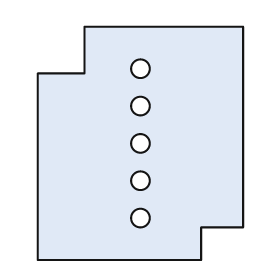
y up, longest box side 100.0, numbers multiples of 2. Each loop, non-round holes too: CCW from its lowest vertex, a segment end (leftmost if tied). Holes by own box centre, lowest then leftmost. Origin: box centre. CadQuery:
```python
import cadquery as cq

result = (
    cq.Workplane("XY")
    .moveTo(-44.0, -50.0)
    .lineTo(26.0, -50.0)
    .lineTo(26.0, -36.0)
    .lineTo(44.0, -36.0)
    .lineTo(44.0, 50.0)
    .lineTo(-24.0, 50.0)
    .lineTo(-24.0, 30.0)
    .lineTo(-44.0, 30.0)
    .close()
    .moveTo(0.0, -32.0)
    .circle(4.0)
    .moveTo(0.0, -16.0)
    .circle(4.0)
    .moveTo(0.0, 0.0)
    .circle(4.0)
    .moveTo(0.0, 16.0)
    .circle(4.0)
    .moveTo(0.0, 32.0)
    .circle(4.0)
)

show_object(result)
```